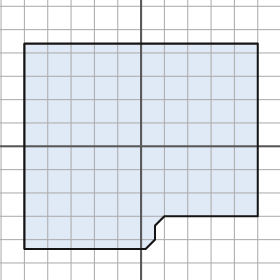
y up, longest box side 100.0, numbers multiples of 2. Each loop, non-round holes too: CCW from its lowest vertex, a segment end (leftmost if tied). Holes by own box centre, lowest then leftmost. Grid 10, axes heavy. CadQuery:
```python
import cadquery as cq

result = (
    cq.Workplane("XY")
    .moveTo(-50.0, -44.0)
    .lineTo(2.0, -44.0)
    .lineTo(6.0, -40.0)
    .lineTo(6.0, -34.0)
    .lineTo(10.0, -30.0)
    .lineTo(50.0, -30.0)
    .lineTo(50.0, 44.0)
    .lineTo(-50.0, 44.0)
    .close()
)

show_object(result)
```